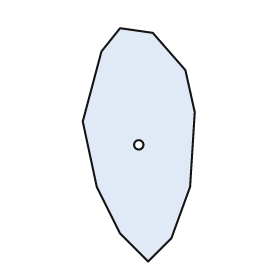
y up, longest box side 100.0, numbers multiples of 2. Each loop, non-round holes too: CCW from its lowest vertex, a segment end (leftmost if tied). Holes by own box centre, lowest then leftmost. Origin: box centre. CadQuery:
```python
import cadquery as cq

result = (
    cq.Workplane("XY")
    .moveTo(4.0, -50.0)
    .lineTo(14.0, -40.0)
    .lineTo(22.0, -18.0)
    .lineTo(24.0, 14.0)
    .lineTo(20.0, 32.0)
    .lineTo(6.0, 48.0)
    .lineTo(-8.0, 50.0)
    .lineTo(-16.0, 40.0)
    .lineTo(-24.0, 10.0)
    .lineTo(-18.0, -18.0)
    .lineTo(-8.0, -38.0)
    .close()
    .moveTo(0.0, 0.0)
    .circle(2.0)
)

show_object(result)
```